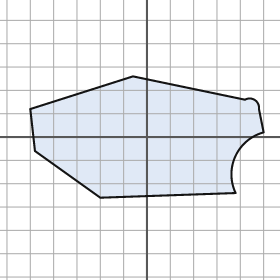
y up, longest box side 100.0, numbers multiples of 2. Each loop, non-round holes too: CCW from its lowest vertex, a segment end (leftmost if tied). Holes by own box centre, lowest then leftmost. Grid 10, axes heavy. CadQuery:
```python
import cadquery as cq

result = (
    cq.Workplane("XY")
    .moveTo(-20.0, -26.0)
    .lineTo(38.0, -24.0)
    .threePointArc((38.0, -8.0), (50.0, 2.0))
    .lineTo(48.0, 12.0)
    .threePointArc((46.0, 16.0), (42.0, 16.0))
    .lineTo(-6.0, 26.0)
    .lineTo(-50.0, 12.0)
    .lineTo(-48.0, -6.0)
    .close()
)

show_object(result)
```